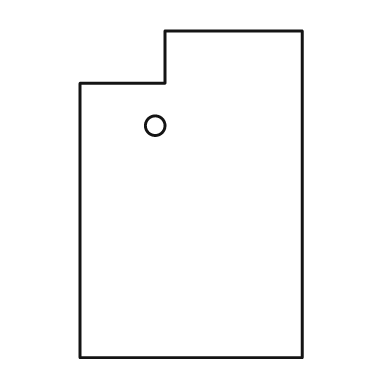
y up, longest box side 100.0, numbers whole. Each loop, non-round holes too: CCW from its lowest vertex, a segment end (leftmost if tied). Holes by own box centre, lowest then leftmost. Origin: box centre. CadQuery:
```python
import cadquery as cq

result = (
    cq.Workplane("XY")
    .moveTo(-34.0, -50.0)
    .lineTo(34.0, -50.0)
    .lineTo(34.0, 50.0)
    .lineTo(-8.0, 50.0)
    .lineTo(-8.0, 34.0)
    .lineTo(-34.0, 34.0)
    .close()
    .moveTo(-11.0, 21.0)
    .circle(3.0)
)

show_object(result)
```